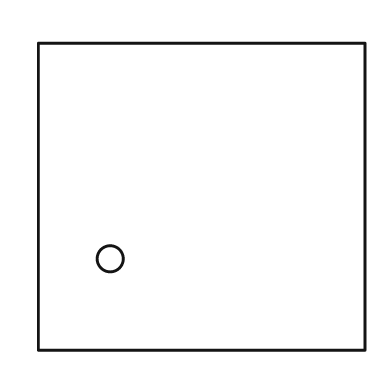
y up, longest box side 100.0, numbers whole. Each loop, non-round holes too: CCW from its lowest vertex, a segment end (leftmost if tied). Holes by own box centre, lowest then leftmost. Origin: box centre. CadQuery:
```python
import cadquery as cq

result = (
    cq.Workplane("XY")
    .moveTo(-50.0, -47.0)
    .lineTo(50.0, -47.0)
    .lineTo(50.0, 47.0)
    .lineTo(-50.0, 47.0)
    .close()
    .moveTo(-28.0, -19.0)
    .circle(4.0)
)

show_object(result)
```